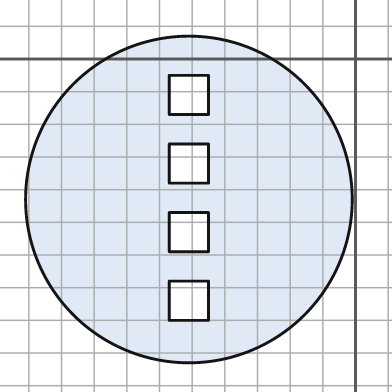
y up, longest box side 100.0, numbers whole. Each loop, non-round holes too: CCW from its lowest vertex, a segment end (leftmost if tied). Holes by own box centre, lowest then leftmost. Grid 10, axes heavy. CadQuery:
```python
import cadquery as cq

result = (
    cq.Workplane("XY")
    .moveTo(-51.0, -43.0)
    .circle(50.0)
    .moveTo(-57.0, -80.0)
    .lineTo(-45.0, -80.0)
    .lineTo(-45.0, -68.0)
    .lineTo(-57.0, -68.0)
    .close()
    .moveTo(-57.0, -59.0)
    .lineTo(-45.0, -59.0)
    .lineTo(-45.0, -47.0)
    .lineTo(-57.0, -47.0)
    .close()
    .moveTo(-57.0, -38.0)
    .lineTo(-45.0, -38.0)
    .lineTo(-45.0, -26.0)
    .lineTo(-57.0, -26.0)
    .close()
    .moveTo(-57.0, -17.0)
    .lineTo(-45.0, -17.0)
    .lineTo(-45.0, -5.0)
    .lineTo(-57.0, -5.0)
    .close()
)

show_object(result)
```